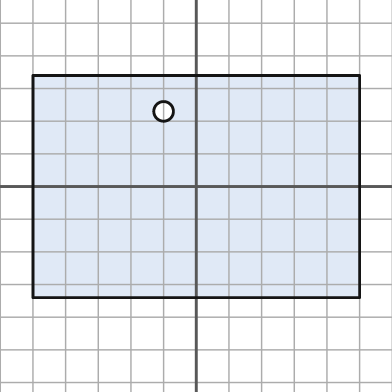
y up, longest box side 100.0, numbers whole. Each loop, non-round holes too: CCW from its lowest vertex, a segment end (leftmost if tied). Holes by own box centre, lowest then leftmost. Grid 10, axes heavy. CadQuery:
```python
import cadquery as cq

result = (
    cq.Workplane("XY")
    .moveTo(-50.0, -34.0)
    .lineTo(50.0, -34.0)
    .lineTo(50.0, 34.0)
    .lineTo(-50.0, 34.0)
    .close()
    .moveTo(-10.0, 23.0)
    .circle(3.0)
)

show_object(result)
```